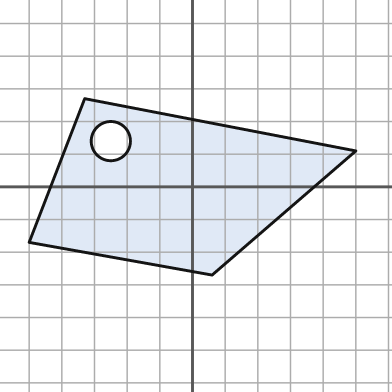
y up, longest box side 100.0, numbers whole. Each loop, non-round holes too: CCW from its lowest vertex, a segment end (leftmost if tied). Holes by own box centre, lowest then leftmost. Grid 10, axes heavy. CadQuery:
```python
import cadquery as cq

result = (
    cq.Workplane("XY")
    .moveTo(6.0, -27.0)
    .lineTo(50.0, 11.0)
    .lineTo(-33.0, 27.0)
    .lineTo(-50.0, -17.0)
    .close()
    .moveTo(-25.0, 14.0)
    .circle(6.0)
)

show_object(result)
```